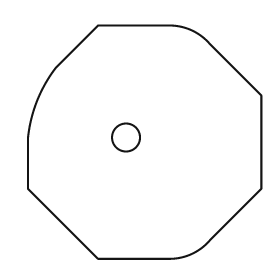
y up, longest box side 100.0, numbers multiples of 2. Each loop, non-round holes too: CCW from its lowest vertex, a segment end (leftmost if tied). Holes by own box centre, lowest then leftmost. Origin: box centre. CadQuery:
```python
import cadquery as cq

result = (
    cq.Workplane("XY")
    .moveTo(-20.0, -50.0)
    .lineTo(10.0, -50.0)
    .threePointArc((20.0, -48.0), (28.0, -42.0))
    .lineTo(50.0, -20.0)
    .lineTo(50.0, 20.0)
    .lineTo(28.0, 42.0)
    .threePointArc((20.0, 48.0), (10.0, 50.0))
    .lineTo(-20.0, 50.0)
    .lineTo(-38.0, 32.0)
    .threePointArc((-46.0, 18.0), (-50.0, 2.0))
    .lineTo(-50.0, -20.0)
    .close()
    .moveTo(-8.0, 2.0)
    .circle(6.0)
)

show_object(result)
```